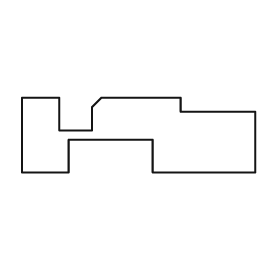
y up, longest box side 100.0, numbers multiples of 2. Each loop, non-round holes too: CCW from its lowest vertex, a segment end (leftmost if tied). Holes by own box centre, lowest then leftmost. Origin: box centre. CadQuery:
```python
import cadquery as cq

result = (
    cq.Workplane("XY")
    .moveTo(-50.0, -16.0)
    .lineTo(-30.0, -16.0)
    .lineTo(-30.0, -2.0)
    .lineTo(6.0, -2.0)
    .lineTo(6.0, -16.0)
    .lineTo(50.0, -16.0)
    .lineTo(50.0, 10.0)
    .lineTo(18.0, 10.0)
    .lineTo(18.0, 16.0)
    .lineTo(-16.0, 16.0)
    .lineTo(-20.0, 12.0)
    .lineTo(-20.0, 2.0)
    .lineTo(-34.0, 2.0)
    .lineTo(-34.0, 16.0)
    .lineTo(-50.0, 16.0)
    .close()
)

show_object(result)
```